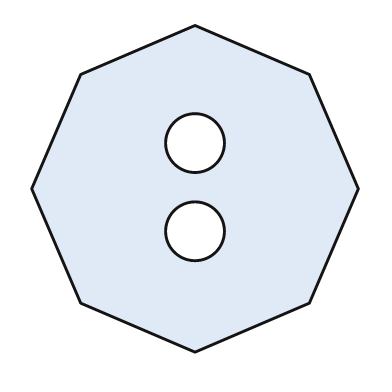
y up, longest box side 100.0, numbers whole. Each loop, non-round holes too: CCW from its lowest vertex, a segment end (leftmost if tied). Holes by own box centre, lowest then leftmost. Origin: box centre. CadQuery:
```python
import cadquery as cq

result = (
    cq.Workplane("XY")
    .moveTo(0.0, -50.0)
    .lineTo(35.0, -35.0)
    .lineTo(50.0, 0.0)
    .lineTo(35.0, 35.0)
    .lineTo(0.0, 50.0)
    .lineTo(-35.0, 35.0)
    .lineTo(-50.0, 0.0)
    .lineTo(-35.0, -35.0)
    .close()
    .moveTo(0.0, -13.0)
    .circle(9.0)
    .moveTo(0.0, 14.0)
    .circle(9.0)
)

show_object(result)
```